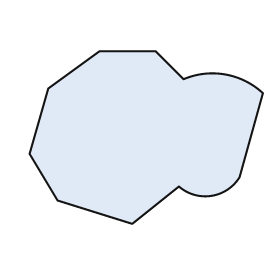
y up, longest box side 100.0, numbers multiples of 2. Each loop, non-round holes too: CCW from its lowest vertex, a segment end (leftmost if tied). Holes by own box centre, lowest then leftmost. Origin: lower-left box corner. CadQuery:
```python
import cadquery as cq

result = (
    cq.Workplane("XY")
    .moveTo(44.0, 0.0)
    .lineTo(64.0, 16.0)
    .threePointArc((78.0, 12.0), (90.0, 20.0))
    .lineTo(100.0, 56.0)
    .threePointArc((84.0, 64.0), (66.0, 62.0))
    .lineTo(54.0, 74.0)
    .lineTo(30.0, 74.0)
    .lineTo(8.0, 58.0)
    .lineTo(0.0, 30.0)
    .lineTo(12.0, 10.0)
    .close()
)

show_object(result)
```